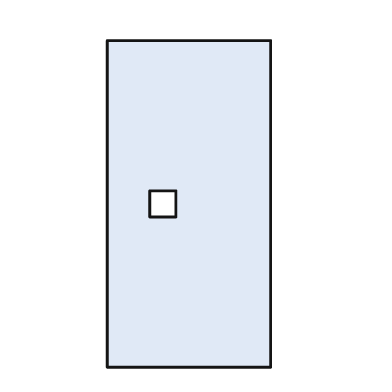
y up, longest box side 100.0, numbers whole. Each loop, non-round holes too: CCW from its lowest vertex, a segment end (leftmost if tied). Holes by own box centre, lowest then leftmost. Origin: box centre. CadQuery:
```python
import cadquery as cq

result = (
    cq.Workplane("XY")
    .moveTo(-25.0, -50.0)
    .lineTo(25.0, -50.0)
    .lineTo(25.0, 50.0)
    .lineTo(-25.0, 50.0)
    .close()
    .moveTo(-12.0, -4.0)
    .lineTo(-4.0, -4.0)
    .lineTo(-4.0, 4.0)
    .lineTo(-12.0, 4.0)
    .close()
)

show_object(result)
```